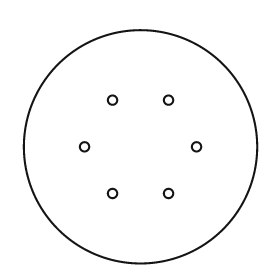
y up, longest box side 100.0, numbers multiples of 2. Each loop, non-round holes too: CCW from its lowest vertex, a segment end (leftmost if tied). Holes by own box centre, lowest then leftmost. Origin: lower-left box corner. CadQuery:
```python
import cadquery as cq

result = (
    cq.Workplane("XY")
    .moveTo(50.0, 50.0)
    .circle(50.0)
    .moveTo(38.0, 30.0)
    .circle(2.0)
    .moveTo(62.0, 30.0)
    .circle(2.0)
    .moveTo(26.0, 50.0)
    .circle(2.0)
    .moveTo(74.0, 50.0)
    .circle(2.0)
    .moveTo(38.0, 70.0)
    .circle(2.0)
    .moveTo(62.0, 70.0)
    .circle(2.0)
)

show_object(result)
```